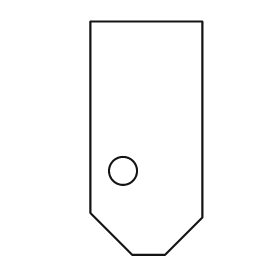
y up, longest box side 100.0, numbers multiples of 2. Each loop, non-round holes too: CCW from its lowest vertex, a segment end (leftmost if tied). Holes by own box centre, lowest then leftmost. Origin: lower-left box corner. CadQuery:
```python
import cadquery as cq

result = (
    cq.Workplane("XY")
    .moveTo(18.0, 0.0)
    .lineTo(32.0, 0.0)
    .lineTo(48.0, 16.0)
    .lineTo(48.0, 100.0)
    .lineTo(0.0, 100.0)
    .lineTo(0.0, 18.0)
    .close()
    .moveTo(14.0, 36.0)
    .circle(6.0)
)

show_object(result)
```